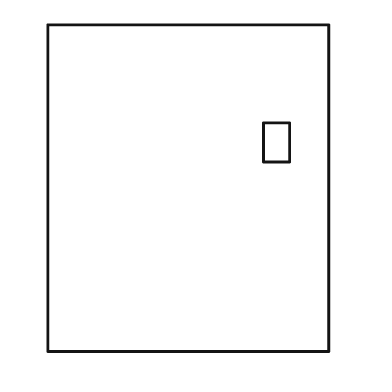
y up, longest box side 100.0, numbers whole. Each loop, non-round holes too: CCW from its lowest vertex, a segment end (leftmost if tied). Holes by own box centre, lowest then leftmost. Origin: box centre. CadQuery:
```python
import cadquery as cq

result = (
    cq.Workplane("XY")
    .moveTo(-43.0, -50.0)
    .lineTo(43.0, -50.0)
    .lineTo(43.0, 50.0)
    .lineTo(-43.0, 50.0)
    .close()
    .moveTo(23.0, 8.0)
    .lineTo(31.0, 8.0)
    .lineTo(31.0, 20.0)
    .lineTo(23.0, 20.0)
    .close()
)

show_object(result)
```